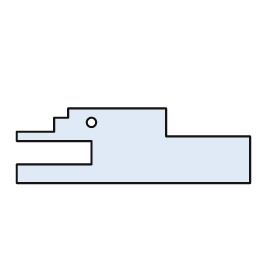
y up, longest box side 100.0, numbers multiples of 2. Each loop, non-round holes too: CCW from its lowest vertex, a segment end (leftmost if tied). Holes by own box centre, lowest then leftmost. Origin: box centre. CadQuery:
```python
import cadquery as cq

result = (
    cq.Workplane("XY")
    .moveTo(-50.0, -16.0)
    .lineTo(50.0, -16.0)
    .lineTo(50.0, 4.0)
    .lineTo(14.0, 4.0)
    .lineTo(14.0, 16.0)
    .lineTo(-28.0, 16.0)
    .lineTo(-28.0, 12.0)
    .lineTo(-34.0, 12.0)
    .lineTo(-34.0, 6.0)
    .lineTo(-50.0, 6.0)
    .lineTo(-50.0, 2.0)
    .lineTo(-18.0, 2.0)
    .lineTo(-18.0, -8.0)
    .lineTo(-50.0, -8.0)
    .close()
    .moveTo(-18.0, 10.0)
    .circle(2.0)
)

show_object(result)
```